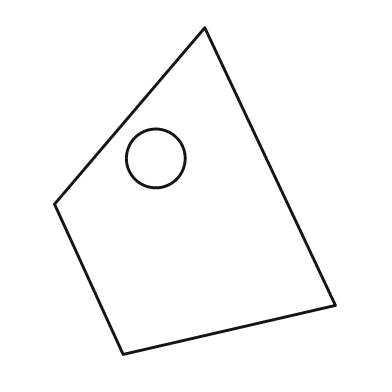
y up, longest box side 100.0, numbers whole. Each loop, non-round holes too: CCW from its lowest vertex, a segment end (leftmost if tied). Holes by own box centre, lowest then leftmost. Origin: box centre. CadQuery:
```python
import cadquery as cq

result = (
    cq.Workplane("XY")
    .moveTo(-22.0, -50.0)
    .lineTo(43.0, -35.0)
    .lineTo(3.0, 50.0)
    .lineTo(-43.0, -4.0)
    .close()
    .moveTo(-12.0, 10.0)
    .circle(9.0)
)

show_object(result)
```